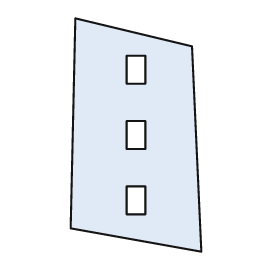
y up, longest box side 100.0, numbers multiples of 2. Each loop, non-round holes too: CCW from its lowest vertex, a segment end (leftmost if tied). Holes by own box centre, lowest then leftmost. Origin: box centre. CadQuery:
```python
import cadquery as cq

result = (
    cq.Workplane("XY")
    .moveTo(28.0, -50.0)
    .lineTo(24.0, 38.0)
    .lineTo(-26.0, 50.0)
    .lineTo(-28.0, -40.0)
    .close()
    .moveTo(-4.0, -34.0)
    .lineTo(4.0, -34.0)
    .lineTo(4.0, -22.0)
    .lineTo(-4.0, -22.0)
    .close()
    .moveTo(-4.0, -6.0)
    .lineTo(4.0, -6.0)
    .lineTo(4.0, 6.0)
    .lineTo(-4.0, 6.0)
    .close()
    .moveTo(-4.0, 22.0)
    .lineTo(4.0, 22.0)
    .lineTo(4.0, 34.0)
    .lineTo(-4.0, 34.0)
    .close()
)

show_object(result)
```